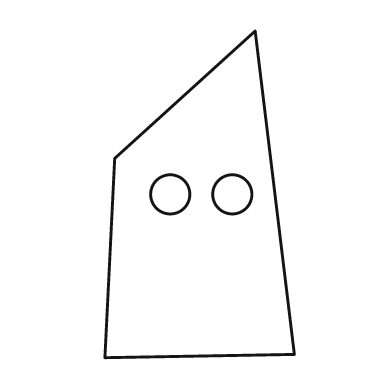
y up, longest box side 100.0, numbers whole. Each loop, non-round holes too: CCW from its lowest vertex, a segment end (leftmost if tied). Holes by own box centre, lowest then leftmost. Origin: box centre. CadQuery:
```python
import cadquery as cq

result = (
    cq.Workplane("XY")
    .moveTo(-29.0, -50.0)
    .lineTo(29.0, -49.0)
    .lineTo(17.0, 50.0)
    .lineTo(-26.0, 11.0)
    .close()
    .moveTo(-9.0, 0.0)
    .circle(6.0)
    .moveTo(10.0, 0.0)
    .circle(6.0)
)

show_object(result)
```